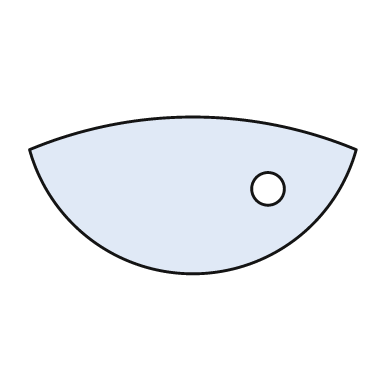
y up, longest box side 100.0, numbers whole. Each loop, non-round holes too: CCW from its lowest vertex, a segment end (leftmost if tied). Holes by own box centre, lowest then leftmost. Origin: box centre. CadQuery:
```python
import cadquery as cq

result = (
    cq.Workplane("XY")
    .moveTo(-50.0, 14.0)
    .threePointArc((0.0, -24.0), (50.0, 14.0))
    .threePointArc((0.0, 24.0), (-50.0, 14.0))
    .close()
    .moveTo(23.0, 2.0)
    .circle(5.0)
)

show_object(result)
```